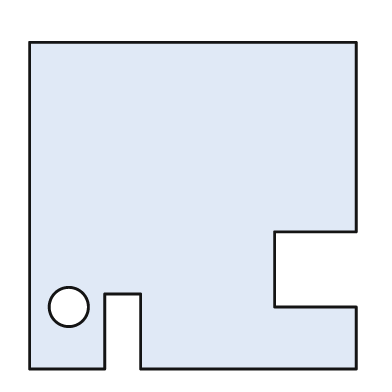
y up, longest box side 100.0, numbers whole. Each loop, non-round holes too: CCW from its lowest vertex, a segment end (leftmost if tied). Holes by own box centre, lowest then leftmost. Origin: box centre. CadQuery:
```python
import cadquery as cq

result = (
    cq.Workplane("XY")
    .moveTo(-50.0, -50.0)
    .lineTo(-27.0, -50.0)
    .lineTo(-27.0, -27.0)
    .lineTo(-16.0, -27.0)
    .lineTo(-16.0, -50.0)
    .lineTo(50.0, -50.0)
    .lineTo(50.0, -31.0)
    .lineTo(25.0, -31.0)
    .lineTo(25.0, -8.0)
    .lineTo(50.0, -8.0)
    .lineTo(50.0, 50.0)
    .lineTo(-50.0, 50.0)
    .close()
    .moveTo(-38.0, -31.0)
    .circle(6.0)
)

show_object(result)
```